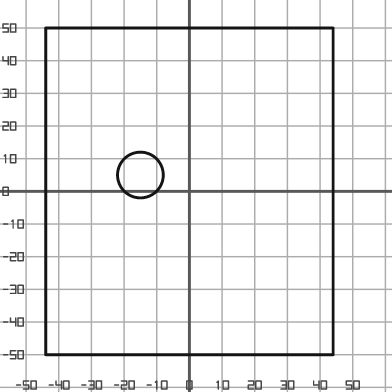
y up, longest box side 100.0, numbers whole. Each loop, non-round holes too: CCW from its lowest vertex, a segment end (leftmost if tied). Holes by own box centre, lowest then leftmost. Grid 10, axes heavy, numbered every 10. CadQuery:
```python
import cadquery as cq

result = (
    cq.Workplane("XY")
    .moveTo(-44.0, -50.0)
    .lineTo(44.0, -50.0)
    .lineTo(44.0, 50.0)
    .lineTo(-44.0, 50.0)
    .close()
    .moveTo(-15.0, 5.0)
    .circle(7.0)
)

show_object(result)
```